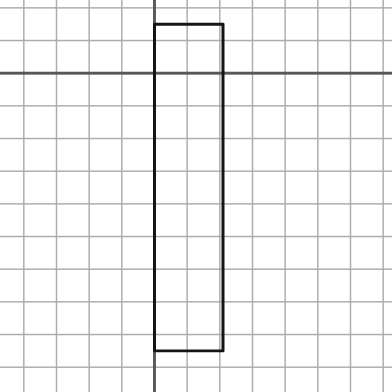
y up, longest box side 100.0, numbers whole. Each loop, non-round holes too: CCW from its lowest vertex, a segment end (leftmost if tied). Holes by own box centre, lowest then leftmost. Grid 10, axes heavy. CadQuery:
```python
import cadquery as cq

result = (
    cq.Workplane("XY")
    .moveTo(0.0, -85.0)
    .lineTo(21.0, -85.0)
    .lineTo(21.0, 15.0)
    .lineTo(0.0, 15.0)
    .close()
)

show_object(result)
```